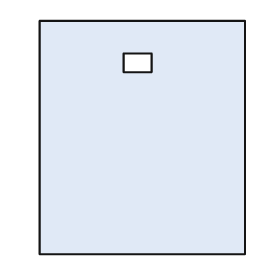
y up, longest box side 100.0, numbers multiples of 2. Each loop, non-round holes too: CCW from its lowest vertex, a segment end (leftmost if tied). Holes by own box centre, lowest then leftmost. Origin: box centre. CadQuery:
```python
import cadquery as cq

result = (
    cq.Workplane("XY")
    .moveTo(-44.0, -50.0)
    .lineTo(44.0, -50.0)
    .lineTo(44.0, 50.0)
    .lineTo(-44.0, 50.0)
    .close()
    .moveTo(-8.0, 28.0)
    .lineTo(4.0, 28.0)
    .lineTo(4.0, 36.0)
    .lineTo(-8.0, 36.0)
    .close()
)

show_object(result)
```